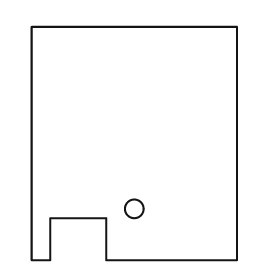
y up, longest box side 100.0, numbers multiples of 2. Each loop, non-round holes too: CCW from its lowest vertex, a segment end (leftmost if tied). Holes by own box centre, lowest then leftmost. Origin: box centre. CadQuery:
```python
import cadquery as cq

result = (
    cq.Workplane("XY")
    .moveTo(-44.0, -50.0)
    .lineTo(-36.0, -50.0)
    .lineTo(-36.0, -32.0)
    .lineTo(-12.0, -32.0)
    .lineTo(-12.0, -50.0)
    .lineTo(44.0, -50.0)
    .lineTo(44.0, 50.0)
    .lineTo(-44.0, 50.0)
    .close()
    .moveTo(0.0, -28.0)
    .circle(4.0)
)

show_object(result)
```